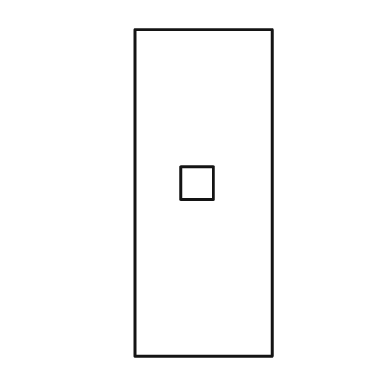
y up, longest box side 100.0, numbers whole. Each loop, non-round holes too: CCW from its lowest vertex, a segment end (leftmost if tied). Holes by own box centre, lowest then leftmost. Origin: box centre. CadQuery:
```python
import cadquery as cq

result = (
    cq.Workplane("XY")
    .moveTo(-21.0, -50.0)
    .lineTo(21.0, -50.0)
    .lineTo(21.0, 50.0)
    .lineTo(-21.0, 50.0)
    .close()
    .moveTo(-7.0, -2.0)
    .lineTo(3.0, -2.0)
    .lineTo(3.0, 8.0)
    .lineTo(-7.0, 8.0)
    .close()
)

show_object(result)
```